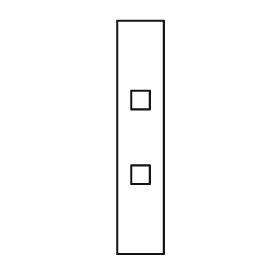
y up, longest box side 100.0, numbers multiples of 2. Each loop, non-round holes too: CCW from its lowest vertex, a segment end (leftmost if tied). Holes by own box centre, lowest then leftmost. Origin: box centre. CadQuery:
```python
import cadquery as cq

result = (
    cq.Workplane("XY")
    .moveTo(-10.0, -50.0)
    .lineTo(10.0, -50.0)
    .lineTo(10.0, 50.0)
    .lineTo(-10.0, 50.0)
    .close()
    .moveTo(-4.0, -20.0)
    .lineTo(4.0, -20.0)
    .lineTo(4.0, -12.0)
    .lineTo(-4.0, -12.0)
    .close()
    .moveTo(-4.0, 12.0)
    .lineTo(4.0, 12.0)
    .lineTo(4.0, 20.0)
    .lineTo(-4.0, 20.0)
    .close()
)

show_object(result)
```